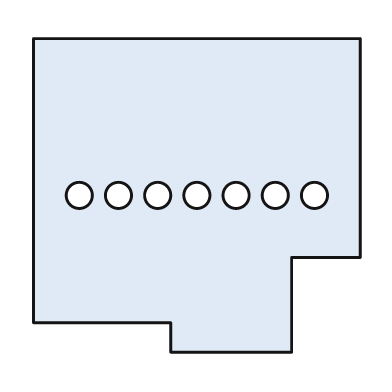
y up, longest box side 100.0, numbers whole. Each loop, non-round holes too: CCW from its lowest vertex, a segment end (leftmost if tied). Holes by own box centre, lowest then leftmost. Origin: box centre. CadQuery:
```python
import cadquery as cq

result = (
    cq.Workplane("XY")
    .moveTo(-8.0, -48.0)
    .lineTo(29.0, -48.0)
    .lineTo(29.0, -19.0)
    .lineTo(50.0, -19.0)
    .lineTo(50.0, 48.0)
    .lineTo(-50.0, 48.0)
    .lineTo(-50.0, -39.0)
    .lineTo(-8.0, -39.0)
    .close()
    .moveTo(-36.0, 0.0)
    .circle(4.0)
    .moveTo(-24.0, 0.0)
    .circle(4.0)
    .moveTo(-12.0, 0.0)
    .circle(4.0)
    .moveTo(0.0, 0.0)
    .circle(4.0)
    .moveTo(12.0, 0.0)
    .circle(4.0)
    .moveTo(24.0, 0.0)
    .circle(4.0)
    .moveTo(36.0, 0.0)
    .circle(4.0)
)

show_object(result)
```